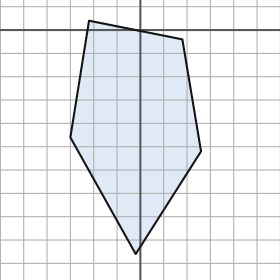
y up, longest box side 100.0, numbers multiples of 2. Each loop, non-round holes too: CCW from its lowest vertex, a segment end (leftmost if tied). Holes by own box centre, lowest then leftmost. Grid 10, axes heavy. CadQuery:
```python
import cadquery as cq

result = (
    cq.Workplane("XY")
    .moveTo(-2.0, -96.0)
    .lineTo(26.0, -52.0)
    .lineTo(18.0, -4.0)
    .lineTo(-22.0, 4.0)
    .lineTo(-30.0, -46.0)
    .close()
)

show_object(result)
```